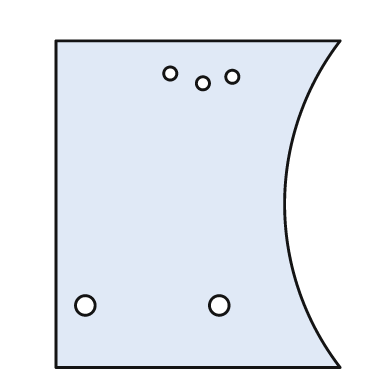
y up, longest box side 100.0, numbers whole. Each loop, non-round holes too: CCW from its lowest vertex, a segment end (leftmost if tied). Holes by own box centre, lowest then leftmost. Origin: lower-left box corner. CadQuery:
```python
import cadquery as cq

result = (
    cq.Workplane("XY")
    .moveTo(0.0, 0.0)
    .lineTo(87.0, 0.0)
    .threePointArc((70.0, 50.0), (87.0, 100.0))
    .lineTo(0.0, 100.0)
    .close()
    .moveTo(9.0, 19.0)
    .circle(3.0)
    .moveTo(50.0, 19.0)
    .circle(3.0)
    .moveTo(45.0, 87.0)
    .circle(2.0)
    .moveTo(54.0, 89.0)
    .circle(2.0)
    .moveTo(35.0, 90.0)
    .circle(2.0)
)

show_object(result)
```